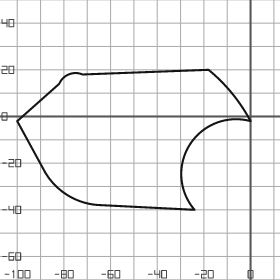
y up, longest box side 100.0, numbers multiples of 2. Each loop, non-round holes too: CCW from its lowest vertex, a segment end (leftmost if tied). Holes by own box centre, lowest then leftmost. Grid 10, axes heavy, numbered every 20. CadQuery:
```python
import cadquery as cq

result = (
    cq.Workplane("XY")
    .moveTo(-24.0, -40.0)
    .threePointArc((-26.0, -12.0), (0.0, -2.0))
    .threePointArc((-8.0, 10.0), (-18.0, 20.0))
    .lineTo(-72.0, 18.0)
    .threePointArc((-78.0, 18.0), (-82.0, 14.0))
    .lineTo(-100.0, -2.0)
    .lineTo(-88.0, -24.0)
    .threePointArc((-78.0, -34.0), (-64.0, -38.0))
    .close()
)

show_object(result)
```